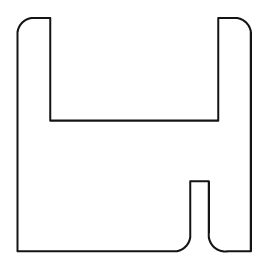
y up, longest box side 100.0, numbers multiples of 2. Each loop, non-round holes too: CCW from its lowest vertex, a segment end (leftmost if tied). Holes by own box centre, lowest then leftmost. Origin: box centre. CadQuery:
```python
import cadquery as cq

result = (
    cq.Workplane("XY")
    .moveTo(-50.0, -50.0)
    .lineTo(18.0, -50.0)
    .threePointArc((22.0, -48.0), (24.0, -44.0))
    .lineTo(24.0, -20.0)
    .lineTo(32.0, -20.0)
    .lineTo(32.0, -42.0)
    .threePointArc((34.0, -48.0), (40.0, -50.0))
    .lineTo(50.0, -50.0)
    .lineTo(50.0, 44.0)
    .threePointArc((48.0, 48.0), (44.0, 50.0))
    .lineTo(36.0, 50.0)
    .lineTo(36.0, 6.0)
    .lineTo(-36.0, 6.0)
    .lineTo(-36.0, 50.0)
    .lineTo(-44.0, 50.0)
    .threePointArc((-48.0, 48.0), (-50.0, 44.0))
    .close()
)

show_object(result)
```